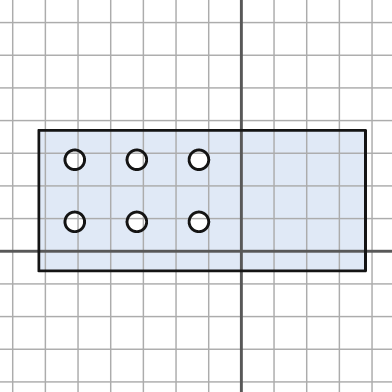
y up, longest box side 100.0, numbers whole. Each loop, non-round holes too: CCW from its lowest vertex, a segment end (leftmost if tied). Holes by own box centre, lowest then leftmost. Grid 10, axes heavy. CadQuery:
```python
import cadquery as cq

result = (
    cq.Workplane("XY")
    .moveTo(-62.0, -6.0)
    .lineTo(38.0, -6.0)
    .lineTo(38.0, 37.0)
    .lineTo(-62.0, 37.0)
    .close()
    .moveTo(-51.0, 9.0)
    .circle(3.0)
    .moveTo(-32.0, 9.0)
    .circle(3.0)
    .moveTo(-13.0, 9.0)
    .circle(3.0)
    .moveTo(-51.0, 28.0)
    .circle(3.0)
    .moveTo(-32.0, 28.0)
    .circle(3.0)
    .moveTo(-13.0, 28.0)
    .circle(3.0)
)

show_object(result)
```